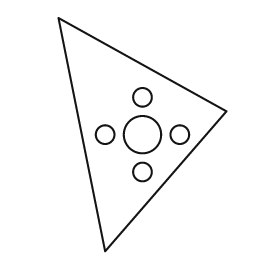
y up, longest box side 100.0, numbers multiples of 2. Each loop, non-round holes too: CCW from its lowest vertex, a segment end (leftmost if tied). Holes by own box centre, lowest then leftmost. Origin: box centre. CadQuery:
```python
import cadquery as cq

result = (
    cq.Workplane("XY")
    .moveTo(-16.0, -50.0)
    .lineTo(36.0, 10.0)
    .lineTo(-36.0, 50.0)
    .close()
    .moveTo(0.0, -16.0)
    .circle(4.0)
    .moveTo(-16.0, 0.0)
    .circle(4.0)
    .moveTo(0.0, 0.0)
    .circle(8.0)
    .moveTo(16.0, 0.0)
    .circle(4.0)
    .moveTo(0.0, 16.0)
    .circle(4.0)
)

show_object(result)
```